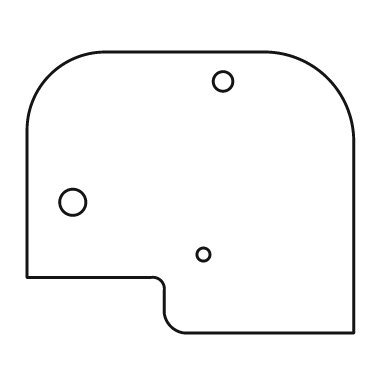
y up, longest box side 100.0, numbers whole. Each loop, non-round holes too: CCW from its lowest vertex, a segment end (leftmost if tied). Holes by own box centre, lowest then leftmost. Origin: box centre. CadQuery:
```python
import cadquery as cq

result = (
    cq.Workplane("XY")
    .moveTo(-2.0, -43.0)
    .lineTo(50.0, -43.0)
    .lineTo(50.0, 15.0)
    .threePointArc((42.0, 35.0), (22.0, 43.0))
    .lineTo(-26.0, 43.0)
    .threePointArc((-43.0, 36.0), (-50.0, 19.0))
    .lineTo(-50.0, -26.0)
    .lineTo(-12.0, -26.0)
    .threePointArc((-9.0, -27.0), (-8.0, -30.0))
    .lineTo(-8.0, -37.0)
    .threePointArc((-6.0, -41.0), (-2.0, -43.0))
    .close()
    .moveTo(4.0, -19.0)
    .circle(2.0)
    .moveTo(-36.0, -3.0)
    .circle(4.0)
    .moveTo(10.0, 34.0)
    .circle(3.0)
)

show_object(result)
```